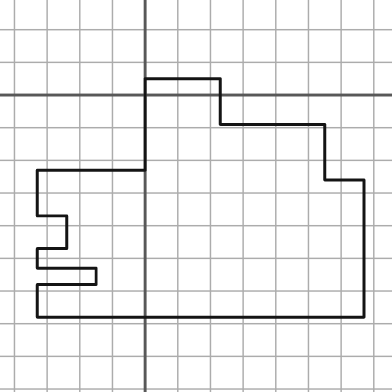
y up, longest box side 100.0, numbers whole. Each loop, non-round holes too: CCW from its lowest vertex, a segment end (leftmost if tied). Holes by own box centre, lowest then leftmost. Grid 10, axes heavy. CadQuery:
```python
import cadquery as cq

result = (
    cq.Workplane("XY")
    .moveTo(-33.0, -68.0)
    .lineTo(67.0, -68.0)
    .lineTo(67.0, -26.0)
    .lineTo(55.0, -26.0)
    .lineTo(55.0, -9.0)
    .lineTo(23.0, -9.0)
    .lineTo(23.0, 5.0)
    .lineTo(0.0, 5.0)
    .lineTo(0.0, -23.0)
    .lineTo(-33.0, -23.0)
    .lineTo(-33.0, -37.0)
    .lineTo(-24.0, -37.0)
    .lineTo(-24.0, -47.0)
    .lineTo(-33.0, -47.0)
    .lineTo(-33.0, -53.0)
    .lineTo(-15.0, -53.0)
    .lineTo(-15.0, -58.0)
    .lineTo(-33.0, -58.0)
    .close()
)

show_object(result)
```